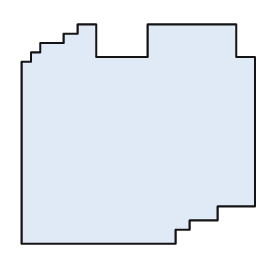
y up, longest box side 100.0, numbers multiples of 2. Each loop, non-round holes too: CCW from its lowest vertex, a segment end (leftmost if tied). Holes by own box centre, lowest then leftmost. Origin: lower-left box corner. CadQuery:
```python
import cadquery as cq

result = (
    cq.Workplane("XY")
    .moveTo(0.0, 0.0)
    .lineTo(66.0, 0.0)
    .lineTo(66.0, 6.0)
    .lineTo(72.0, 6.0)
    .lineTo(72.0, 10.0)
    .lineTo(84.0, 10.0)
    .lineTo(84.0, 16.0)
    .lineTo(100.0, 16.0)
    .lineTo(100.0, 80.0)
    .lineTo(92.0, 80.0)
    .lineTo(92.0, 94.0)
    .lineTo(54.0, 94.0)
    .lineTo(54.0, 80.0)
    .lineTo(32.0, 80.0)
    .lineTo(32.0, 94.0)
    .lineTo(24.0, 94.0)
    .lineTo(24.0, 90.0)
    .lineTo(18.0, 90.0)
    .lineTo(18.0, 86.0)
    .lineTo(8.0, 86.0)
    .lineTo(8.0, 82.0)
    .lineTo(4.0, 82.0)
    .lineTo(4.0, 78.0)
    .lineTo(0.0, 78.0)
    .close()
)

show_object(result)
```